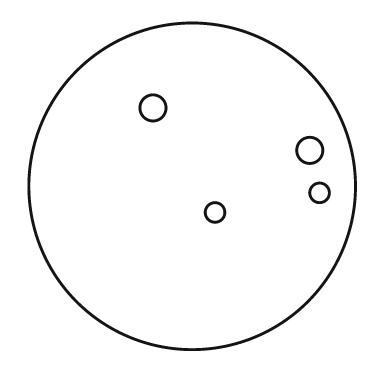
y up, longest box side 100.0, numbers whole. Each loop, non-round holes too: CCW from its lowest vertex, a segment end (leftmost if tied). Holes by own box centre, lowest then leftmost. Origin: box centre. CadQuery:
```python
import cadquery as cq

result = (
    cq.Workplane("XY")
    .moveTo(0.0, 0.0)
    .circle(50.0)
    .moveTo(7.0, -8.0)
    .circle(3.0)
    .moveTo(39.0, -2.0)
    .circle(3.0)
    .moveTo(36.0, 11.0)
    .circle(4.0)
    .moveTo(-12.0, 24.0)
    .circle(4.0)
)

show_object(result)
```